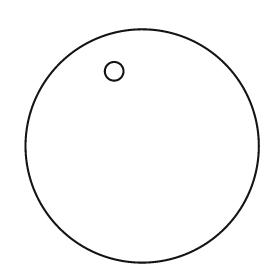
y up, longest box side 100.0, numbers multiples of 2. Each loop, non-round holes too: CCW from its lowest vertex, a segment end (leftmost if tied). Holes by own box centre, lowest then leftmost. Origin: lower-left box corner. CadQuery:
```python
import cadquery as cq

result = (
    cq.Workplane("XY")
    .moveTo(50.0, 50.0)
    .circle(50.0)
    .moveTo(38.0, 82.0)
    .circle(4.0)
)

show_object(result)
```